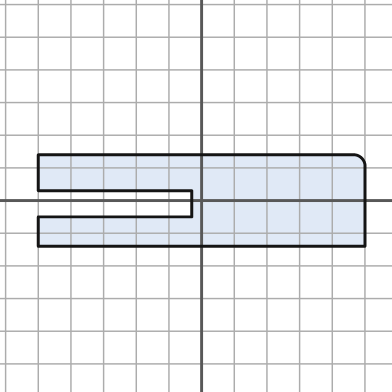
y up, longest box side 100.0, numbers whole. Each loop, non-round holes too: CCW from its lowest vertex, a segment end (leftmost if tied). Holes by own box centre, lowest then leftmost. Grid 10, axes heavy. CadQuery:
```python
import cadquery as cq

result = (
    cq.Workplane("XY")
    .moveTo(-50.0, -14.0)
    .lineTo(50.0, -14.0)
    .lineTo(50.0, 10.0)
    .threePointArc((49.0, 13.0), (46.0, 14.0))
    .lineTo(-50.0, 14.0)
    .lineTo(-50.0, 3.0)
    .lineTo(-3.0, 3.0)
    .lineTo(-3.0, -5.0)
    .lineTo(-50.0, -5.0)
    .close()
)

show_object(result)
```